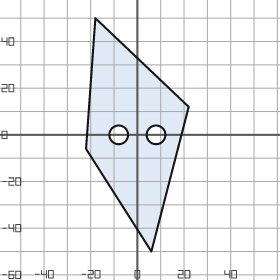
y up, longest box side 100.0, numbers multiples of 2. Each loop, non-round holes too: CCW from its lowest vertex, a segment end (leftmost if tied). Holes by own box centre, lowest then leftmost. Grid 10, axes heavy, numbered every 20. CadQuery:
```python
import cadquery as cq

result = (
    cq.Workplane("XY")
    .moveTo(6.0, -50.0)
    .lineTo(22.0, 12.0)
    .lineTo(-18.0, 50.0)
    .lineTo(-22.0, -6.0)
    .close()
    .moveTo(-8.0, 0.0)
    .circle(4.0)
    .moveTo(8.0, 0.0)
    .circle(4.0)
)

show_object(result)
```